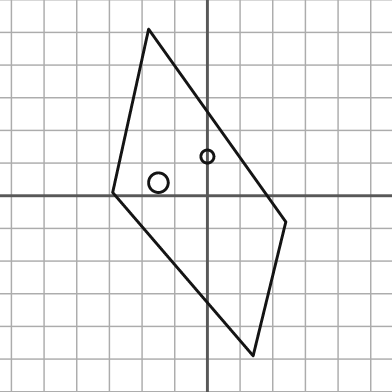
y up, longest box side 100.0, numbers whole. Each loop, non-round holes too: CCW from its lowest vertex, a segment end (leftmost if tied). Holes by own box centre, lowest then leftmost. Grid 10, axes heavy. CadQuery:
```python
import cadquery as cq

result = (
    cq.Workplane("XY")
    .moveTo(14.0, -49.0)
    .lineTo(24.0, -8.0)
    .lineTo(-18.0, 51.0)
    .lineTo(-29.0, 1.0)
    .close()
    .moveTo(-15.0, 4.0)
    .circle(3.0)
    .moveTo(0.0, 12.0)
    .circle(2.0)
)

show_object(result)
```